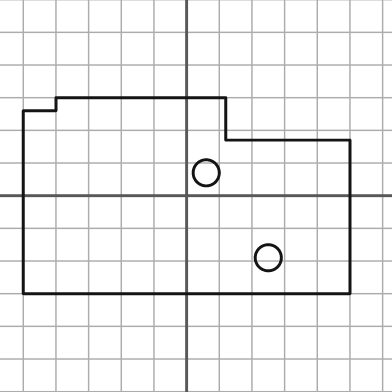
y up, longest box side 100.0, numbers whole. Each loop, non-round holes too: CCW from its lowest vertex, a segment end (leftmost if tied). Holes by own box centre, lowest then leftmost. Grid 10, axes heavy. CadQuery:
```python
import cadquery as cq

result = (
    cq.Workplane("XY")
    .moveTo(-50.0, -30.0)
    .lineTo(50.0, -30.0)
    .lineTo(50.0, 17.0)
    .lineTo(12.0, 17.0)
    .lineTo(12.0, 30.0)
    .lineTo(-40.0, 30.0)
    .lineTo(-40.0, 26.0)
    .lineTo(-50.0, 26.0)
    .close()
    .moveTo(25.0, -19.0)
    .circle(4.0)
    .moveTo(6.0, 7.0)
    .circle(4.0)
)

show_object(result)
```